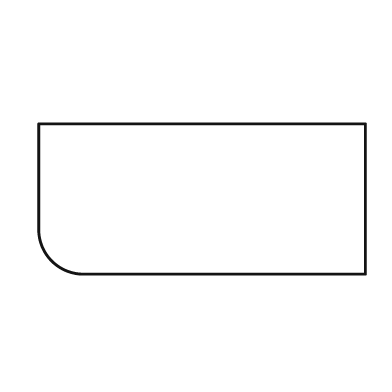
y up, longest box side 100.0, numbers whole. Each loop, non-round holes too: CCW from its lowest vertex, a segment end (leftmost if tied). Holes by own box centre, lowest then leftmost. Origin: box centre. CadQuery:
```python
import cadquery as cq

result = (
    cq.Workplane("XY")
    .moveTo(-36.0, -23.0)
    .lineTo(50.0, -23.0)
    .lineTo(50.0, 23.0)
    .lineTo(-50.0, 23.0)
    .lineTo(-50.0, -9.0)
    .threePointArc((-46.0, -19.0), (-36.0, -23.0))
    .close()
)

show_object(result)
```